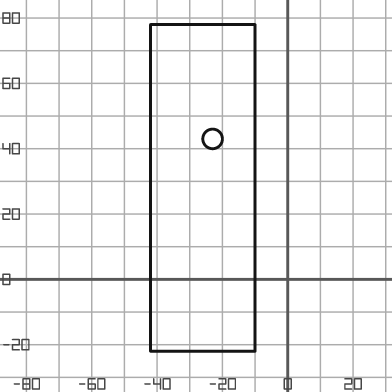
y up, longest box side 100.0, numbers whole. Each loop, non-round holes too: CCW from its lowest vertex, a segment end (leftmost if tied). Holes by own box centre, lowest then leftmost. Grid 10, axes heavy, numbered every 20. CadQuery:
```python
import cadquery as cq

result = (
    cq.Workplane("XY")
    .moveTo(-42.0, -22.0)
    .lineTo(-10.0, -22.0)
    .lineTo(-10.0, 78.0)
    .lineTo(-42.0, 78.0)
    .close()
    .moveTo(-23.0, 43.0)
    .circle(3.0)
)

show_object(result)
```